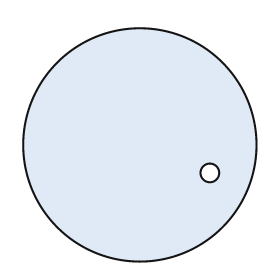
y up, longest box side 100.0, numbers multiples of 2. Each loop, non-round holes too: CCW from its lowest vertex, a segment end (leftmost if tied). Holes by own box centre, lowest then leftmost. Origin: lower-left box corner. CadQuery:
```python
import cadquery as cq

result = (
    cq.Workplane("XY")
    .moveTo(50.0, 50.0)
    .circle(50.0)
    .moveTo(80.0, 38.0)
    .circle(4.0)
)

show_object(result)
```